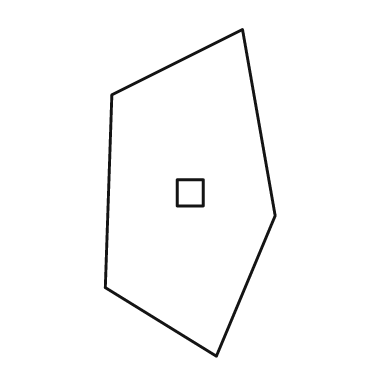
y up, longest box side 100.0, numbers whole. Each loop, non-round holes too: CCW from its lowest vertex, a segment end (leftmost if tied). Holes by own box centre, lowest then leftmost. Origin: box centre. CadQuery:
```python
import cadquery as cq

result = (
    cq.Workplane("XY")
    .moveTo(8.0, -50.0)
    .lineTo(26.0, -7.0)
    .lineTo(16.0, 50.0)
    .lineTo(-24.0, 30.0)
    .lineTo(-26.0, -29.0)
    .close()
    .moveTo(-4.0, -4.0)
    .lineTo(4.0, -4.0)
    .lineTo(4.0, 4.0)
    .lineTo(-4.0, 4.0)
    .close()
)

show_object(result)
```